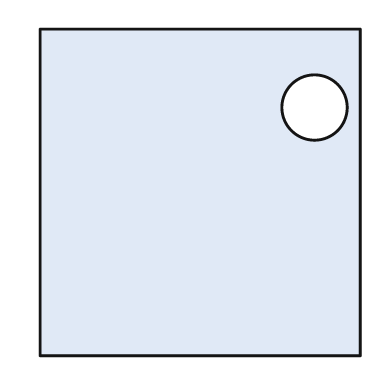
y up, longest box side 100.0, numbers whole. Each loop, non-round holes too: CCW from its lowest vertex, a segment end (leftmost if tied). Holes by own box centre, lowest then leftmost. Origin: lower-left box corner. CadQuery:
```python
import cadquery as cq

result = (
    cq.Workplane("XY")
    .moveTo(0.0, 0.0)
    .lineTo(98.0, 0.0)
    .lineTo(98.0, 100.0)
    .lineTo(0.0, 100.0)
    .close()
    .moveTo(84.0, 76.0)
    .circle(10.0)
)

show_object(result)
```